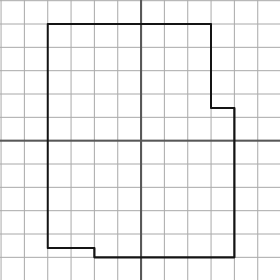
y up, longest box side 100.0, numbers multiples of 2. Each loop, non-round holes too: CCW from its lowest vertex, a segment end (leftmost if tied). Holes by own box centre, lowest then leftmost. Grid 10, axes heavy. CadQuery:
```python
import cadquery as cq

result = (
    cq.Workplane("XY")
    .moveTo(-20.0, -50.0)
    .lineTo(40.0, -50.0)
    .lineTo(40.0, 14.0)
    .lineTo(30.0, 14.0)
    .lineTo(30.0, 50.0)
    .lineTo(-40.0, 50.0)
    .lineTo(-40.0, -46.0)
    .lineTo(-20.0, -46.0)
    .close()
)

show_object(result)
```